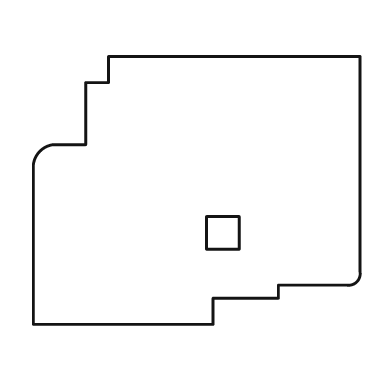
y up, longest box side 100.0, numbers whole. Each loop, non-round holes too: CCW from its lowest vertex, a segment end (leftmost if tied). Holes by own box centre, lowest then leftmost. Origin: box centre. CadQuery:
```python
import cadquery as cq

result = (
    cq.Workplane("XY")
    .moveTo(-50.0, -41.0)
    .lineTo(5.0, -41.0)
    .lineTo(5.0, -33.0)
    .lineTo(25.0, -33.0)
    .lineTo(25.0, -29.0)
    .lineTo(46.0, -29.0)
    .threePointArc((49.0, -28.0), (50.0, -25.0))
    .lineTo(50.0, 41.0)
    .lineTo(-27.0, 41.0)
    .lineTo(-27.0, 33.0)
    .lineTo(-34.0, 33.0)
    .lineTo(-34.0, 14.0)
    .lineTo(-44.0, 14.0)
    .threePointArc((-48.0, 12.0), (-50.0, 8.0))
    .close()
    .moveTo(3.0, -18.0)
    .lineTo(13.0, -18.0)
    .lineTo(13.0, -8.0)
    .lineTo(3.0, -8.0)
    .close()
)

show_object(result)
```